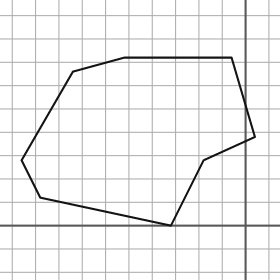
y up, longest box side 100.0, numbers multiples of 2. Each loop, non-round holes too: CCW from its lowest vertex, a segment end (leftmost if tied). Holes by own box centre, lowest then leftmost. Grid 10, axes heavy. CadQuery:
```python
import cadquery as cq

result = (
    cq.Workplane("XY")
    .moveTo(-32.0, 0.0)
    .lineTo(-18.0, 28.0)
    .lineTo(4.0, 38.0)
    .lineTo(-6.0, 72.0)
    .lineTo(-52.0, 72.0)
    .lineTo(-74.0, 66.0)
    .lineTo(-96.0, 28.0)
    .lineTo(-88.0, 12.0)
    .close()
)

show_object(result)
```